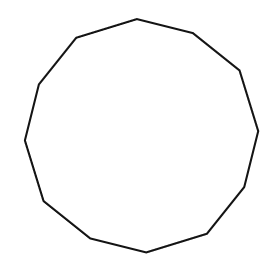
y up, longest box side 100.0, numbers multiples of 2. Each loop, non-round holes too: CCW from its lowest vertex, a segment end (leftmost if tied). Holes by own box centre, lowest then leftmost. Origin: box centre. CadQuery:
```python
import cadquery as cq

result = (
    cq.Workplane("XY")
    .moveTo(2.0, -50.0)
    .lineTo(28.0, -42.0)
    .lineTo(44.0, -22.0)
    .lineTo(50.0, 2.0)
    .lineTo(42.0, 28.0)
    .lineTo(22.0, 44.0)
    .lineTo(-2.0, 50.0)
    .lineTo(-28.0, 42.0)
    .lineTo(-44.0, 22.0)
    .lineTo(-50.0, -2.0)
    .lineTo(-42.0, -28.0)
    .lineTo(-22.0, -44.0)
    .close()
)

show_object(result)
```